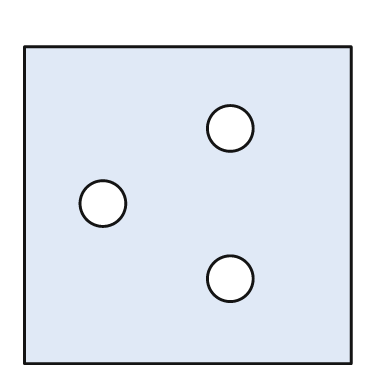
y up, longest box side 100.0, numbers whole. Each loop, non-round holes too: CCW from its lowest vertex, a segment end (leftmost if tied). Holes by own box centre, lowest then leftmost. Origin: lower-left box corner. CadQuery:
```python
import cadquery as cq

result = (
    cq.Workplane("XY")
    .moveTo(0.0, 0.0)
    .lineTo(100.0, 0.0)
    .lineTo(100.0, 97.0)
    .lineTo(0.0, 97.0)
    .close()
    .moveTo(63.0, 26.0)
    .circle(7.0)
    .moveTo(24.0, 49.0)
    .circle(7.0)
    .moveTo(63.0, 72.0)
    .circle(7.0)
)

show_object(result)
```